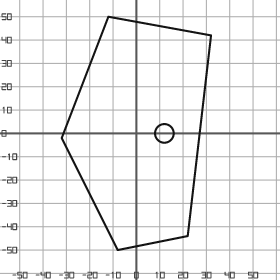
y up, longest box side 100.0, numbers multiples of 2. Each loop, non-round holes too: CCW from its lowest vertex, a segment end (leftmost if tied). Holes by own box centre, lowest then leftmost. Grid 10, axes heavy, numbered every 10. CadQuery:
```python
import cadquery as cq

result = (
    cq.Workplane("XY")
    .moveTo(-8.0, -50.0)
    .lineTo(22.0, -44.0)
    .lineTo(32.0, 42.0)
    .lineTo(-12.0, 50.0)
    .lineTo(-32.0, -2.0)
    .close()
    .moveTo(12.0, 0.0)
    .circle(4.0)
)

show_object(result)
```